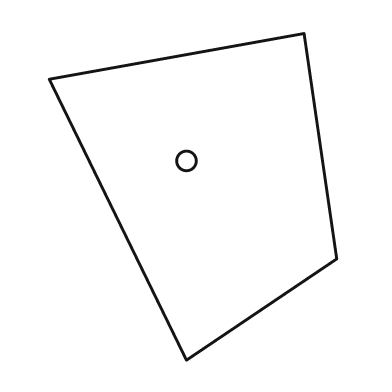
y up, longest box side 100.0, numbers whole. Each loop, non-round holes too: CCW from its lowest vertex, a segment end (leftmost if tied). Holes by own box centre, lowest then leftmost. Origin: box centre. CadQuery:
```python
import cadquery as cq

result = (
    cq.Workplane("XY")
    .moveTo(-2.0, -50.0)
    .lineTo(44.0, -19.0)
    .lineTo(34.0, 50.0)
    .lineTo(-44.0, 36.0)
    .close()
    .moveTo(-2.0, 11.0)
    .circle(3.0)
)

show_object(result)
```